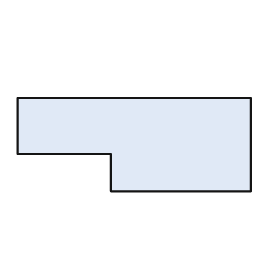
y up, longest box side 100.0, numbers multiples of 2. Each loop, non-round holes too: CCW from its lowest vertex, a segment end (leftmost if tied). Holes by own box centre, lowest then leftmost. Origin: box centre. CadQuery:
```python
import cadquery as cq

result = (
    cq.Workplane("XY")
    .moveTo(-10.0, -20.0)
    .lineTo(50.0, -20.0)
    .lineTo(50.0, 20.0)
    .lineTo(-50.0, 20.0)
    .lineTo(-50.0, -4.0)
    .lineTo(-10.0, -4.0)
    .close()
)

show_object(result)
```